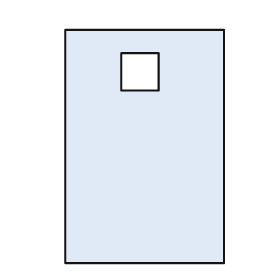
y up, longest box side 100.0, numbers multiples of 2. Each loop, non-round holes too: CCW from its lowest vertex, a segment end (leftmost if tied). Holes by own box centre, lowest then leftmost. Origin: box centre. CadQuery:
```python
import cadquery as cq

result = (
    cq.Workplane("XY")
    .moveTo(-34.0, -50.0)
    .lineTo(34.0, -50.0)
    .lineTo(34.0, 50.0)
    .lineTo(-34.0, 50.0)
    .close()
    .moveTo(-10.0, 24.0)
    .lineTo(6.0, 24.0)
    .lineTo(6.0, 40.0)
    .lineTo(-10.0, 40.0)
    .close()
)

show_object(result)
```